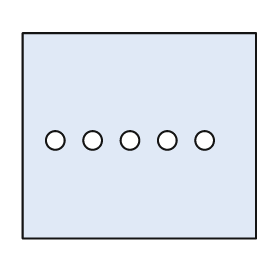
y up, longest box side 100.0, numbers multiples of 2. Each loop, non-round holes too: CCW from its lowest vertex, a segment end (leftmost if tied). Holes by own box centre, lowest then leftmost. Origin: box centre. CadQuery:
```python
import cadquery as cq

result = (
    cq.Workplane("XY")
    .moveTo(-50.0, -44.0)
    .lineTo(50.0, -44.0)
    .lineTo(50.0, 44.0)
    .lineTo(-50.0, 44.0)
    .close()
    .moveTo(-36.0, -2.0)
    .circle(4.0)
    .moveTo(-20.0, -2.0)
    .circle(4.0)
    .moveTo(-4.0, -2.0)
    .circle(4.0)
    .moveTo(12.0, -2.0)
    .circle(4.0)
    .moveTo(28.0, -2.0)
    .circle(4.0)
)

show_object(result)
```